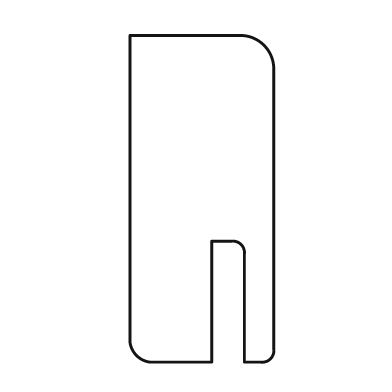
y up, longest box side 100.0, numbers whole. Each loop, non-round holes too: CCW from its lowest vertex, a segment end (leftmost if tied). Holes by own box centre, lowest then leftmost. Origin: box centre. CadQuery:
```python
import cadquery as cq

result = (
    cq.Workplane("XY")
    .moveTo(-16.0, -50.0)
    .lineTo(3.0, -50.0)
    .lineTo(3.0, -13.0)
    .lineTo(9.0, -13.0)
    .threePointArc((12.0, -14.0), (13.0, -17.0))
    .lineTo(13.0, -50.0)
    .lineTo(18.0, -50.0)
    .threePointArc((21.0, -49.0), (22.0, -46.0))
    .lineTo(22.0, 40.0)
    .threePointArc((19.0, 47.0), (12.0, 50.0))
    .lineTo(-22.0, 50.0)
    .lineTo(-22.0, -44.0)
    .threePointArc((-20.0, -48.0), (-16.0, -50.0))
    .close()
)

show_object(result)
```